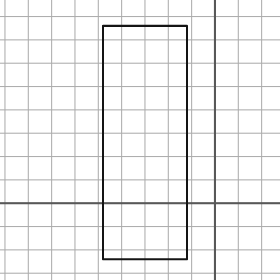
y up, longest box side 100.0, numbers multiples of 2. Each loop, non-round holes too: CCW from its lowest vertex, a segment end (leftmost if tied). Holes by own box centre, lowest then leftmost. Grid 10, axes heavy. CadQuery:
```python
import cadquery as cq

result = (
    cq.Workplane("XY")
    .moveTo(-48.0, -24.0)
    .lineTo(-12.0, -24.0)
    .lineTo(-12.0, 76.0)
    .lineTo(-48.0, 76.0)
    .close()
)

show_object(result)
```